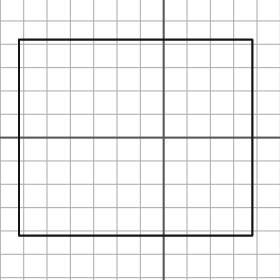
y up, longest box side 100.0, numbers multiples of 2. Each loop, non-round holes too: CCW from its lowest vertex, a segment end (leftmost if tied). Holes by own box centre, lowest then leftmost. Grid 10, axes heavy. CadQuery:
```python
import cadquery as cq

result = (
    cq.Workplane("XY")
    .moveTo(-62.0, -42.0)
    .lineTo(38.0, -42.0)
    .lineTo(38.0, 42.0)
    .lineTo(-62.0, 42.0)
    .close()
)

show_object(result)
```